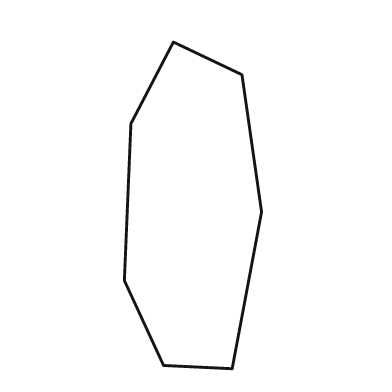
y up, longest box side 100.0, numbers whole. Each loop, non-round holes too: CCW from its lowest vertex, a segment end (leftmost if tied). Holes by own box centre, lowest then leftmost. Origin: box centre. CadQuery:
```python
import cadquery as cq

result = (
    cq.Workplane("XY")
    .moveTo(12.0, -50.0)
    .lineTo(21.0, -2.0)
    .lineTo(15.0, 40.0)
    .lineTo(-6.0, 50.0)
    .lineTo(-19.0, 25.0)
    .lineTo(-21.0, -23.0)
    .lineTo(-9.0, -49.0)
    .close()
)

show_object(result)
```